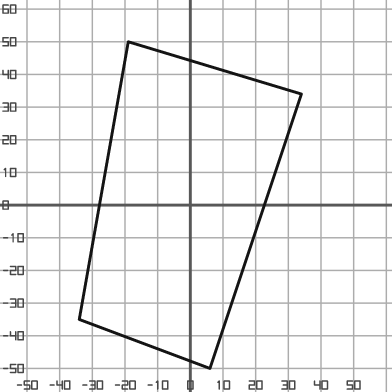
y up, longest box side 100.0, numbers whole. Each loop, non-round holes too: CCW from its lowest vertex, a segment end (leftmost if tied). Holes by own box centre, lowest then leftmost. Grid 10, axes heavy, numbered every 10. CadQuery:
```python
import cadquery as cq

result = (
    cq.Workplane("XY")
    .moveTo(6.0, -50.0)
    .lineTo(34.0, 34.0)
    .lineTo(-19.0, 50.0)
    .lineTo(-34.0, -35.0)
    .close()
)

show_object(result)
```